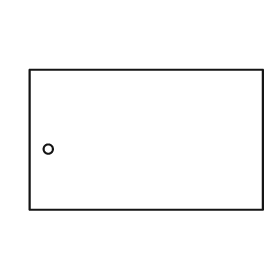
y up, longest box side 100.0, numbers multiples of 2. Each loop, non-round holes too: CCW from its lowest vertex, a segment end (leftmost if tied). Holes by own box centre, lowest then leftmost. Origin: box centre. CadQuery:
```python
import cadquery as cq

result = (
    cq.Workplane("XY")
    .moveTo(-50.0, -30.0)
    .lineTo(50.0, -30.0)
    .lineTo(50.0, 30.0)
    .lineTo(-50.0, 30.0)
    .close()
    .moveTo(-42.0, -4.0)
    .circle(2.0)
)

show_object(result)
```